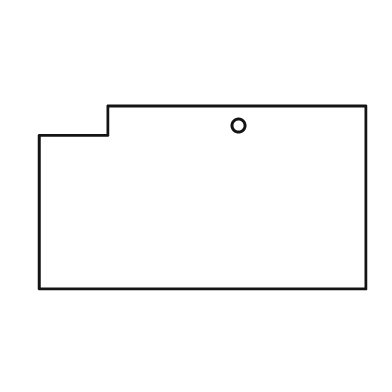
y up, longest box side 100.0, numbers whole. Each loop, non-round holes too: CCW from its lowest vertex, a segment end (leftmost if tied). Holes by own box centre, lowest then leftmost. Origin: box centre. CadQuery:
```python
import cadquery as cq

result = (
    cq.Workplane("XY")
    .moveTo(-50.0, -28.0)
    .lineTo(50.0, -28.0)
    .lineTo(50.0, 28.0)
    .lineTo(-29.0, 28.0)
    .lineTo(-29.0, 19.0)
    .lineTo(-50.0, 19.0)
    .close()
    .moveTo(11.0, 22.0)
    .circle(2.0)
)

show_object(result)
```